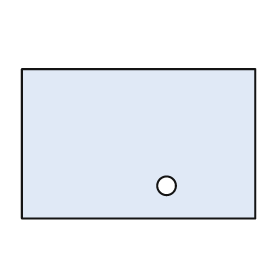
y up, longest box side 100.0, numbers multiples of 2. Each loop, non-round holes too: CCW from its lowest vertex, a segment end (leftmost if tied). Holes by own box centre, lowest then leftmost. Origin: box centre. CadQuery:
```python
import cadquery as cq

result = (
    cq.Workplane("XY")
    .moveTo(-50.0, -32.0)
    .lineTo(50.0, -32.0)
    .lineTo(50.0, 32.0)
    .lineTo(-50.0, 32.0)
    .close()
    .moveTo(12.0, -18.0)
    .circle(4.0)
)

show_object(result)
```